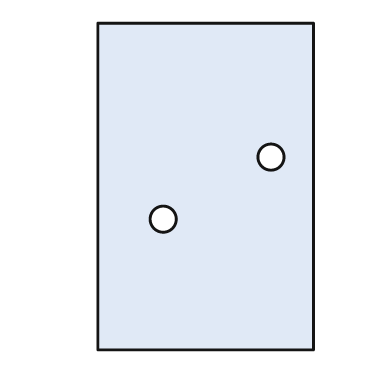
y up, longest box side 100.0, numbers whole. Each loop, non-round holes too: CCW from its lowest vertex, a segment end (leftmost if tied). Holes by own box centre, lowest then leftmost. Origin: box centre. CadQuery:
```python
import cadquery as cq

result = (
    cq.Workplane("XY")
    .moveTo(-33.0, -50.0)
    .lineTo(33.0, -50.0)
    .lineTo(33.0, 50.0)
    .lineTo(-33.0, 50.0)
    .close()
    .moveTo(-13.0, -10.0)
    .circle(4.0)
    .moveTo(20.0, 9.0)
    .circle(4.0)
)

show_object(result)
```